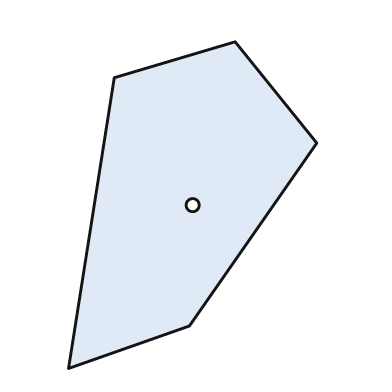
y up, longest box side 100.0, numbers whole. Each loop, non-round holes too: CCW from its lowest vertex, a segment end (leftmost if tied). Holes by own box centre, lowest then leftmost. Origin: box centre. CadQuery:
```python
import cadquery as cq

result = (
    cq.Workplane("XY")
    .moveTo(-38.0, -50.0)
    .lineTo(-1.0, -37.0)
    .lineTo(38.0, 19.0)
    .lineTo(13.0, 50.0)
    .lineTo(-24.0, 39.0)
    .close()
    .moveTo(0.0, 0.0)
    .circle(2.0)
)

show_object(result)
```